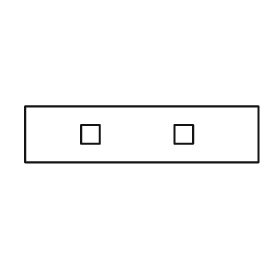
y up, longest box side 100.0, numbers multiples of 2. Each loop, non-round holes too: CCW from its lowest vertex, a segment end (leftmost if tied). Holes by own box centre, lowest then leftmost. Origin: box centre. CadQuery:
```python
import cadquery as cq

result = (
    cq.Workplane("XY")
    .moveTo(-50.0, -12.0)
    .lineTo(50.0, -12.0)
    .lineTo(50.0, 12.0)
    .lineTo(-50.0, 12.0)
    .close()
    .moveTo(-26.0, -4.0)
    .lineTo(-18.0, -4.0)
    .lineTo(-18.0, 4.0)
    .lineTo(-26.0, 4.0)
    .close()
    .moveTo(14.0, -4.0)
    .lineTo(22.0, -4.0)
    .lineTo(22.0, 4.0)
    .lineTo(14.0, 4.0)
    .close()
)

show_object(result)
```